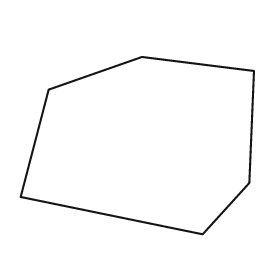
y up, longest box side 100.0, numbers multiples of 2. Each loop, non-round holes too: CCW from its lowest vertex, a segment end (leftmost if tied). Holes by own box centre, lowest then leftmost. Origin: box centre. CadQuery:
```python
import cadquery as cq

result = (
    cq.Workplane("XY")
    .moveTo(28.0, -38.0)
    .lineTo(48.0, -16.0)
    .lineTo(50.0, 32.0)
    .lineTo(2.0, 38.0)
    .lineTo(-38.0, 24.0)
    .lineTo(-50.0, -22.0)
    .close()
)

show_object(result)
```